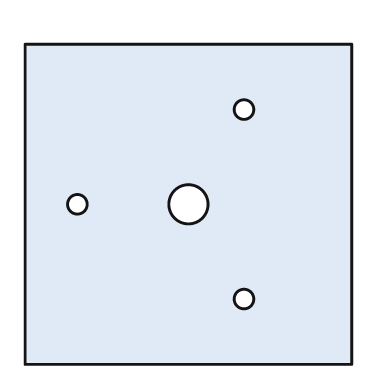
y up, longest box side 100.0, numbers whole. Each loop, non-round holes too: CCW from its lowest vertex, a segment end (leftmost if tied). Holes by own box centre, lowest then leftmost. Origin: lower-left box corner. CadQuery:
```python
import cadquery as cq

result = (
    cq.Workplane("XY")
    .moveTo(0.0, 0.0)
    .lineTo(100.0, 0.0)
    .lineTo(100.0, 98.0)
    .lineTo(0.0, 98.0)
    .close()
    .moveTo(67.0, 20.0)
    .circle(3.0)
    .moveTo(16.0, 49.0)
    .circle(3.0)
    .moveTo(50.0, 49.0)
    .circle(6.0)
    .moveTo(67.0, 78.0)
    .circle(3.0)
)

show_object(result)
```